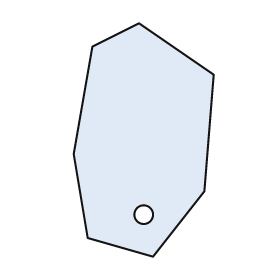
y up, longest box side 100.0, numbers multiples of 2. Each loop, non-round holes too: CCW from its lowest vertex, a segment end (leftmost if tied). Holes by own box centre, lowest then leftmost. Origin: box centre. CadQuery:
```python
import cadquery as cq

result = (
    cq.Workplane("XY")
    .moveTo(4.0, -50.0)
    .lineTo(26.0, -22.0)
    .lineTo(30.0, 28.0)
    .lineTo(-2.0, 50.0)
    .lineTo(-22.0, 40.0)
    .lineTo(-30.0, -6.0)
    .lineTo(-24.0, -42.0)
    .close()
    .moveTo(0.0, -32.0)
    .circle(4.0)
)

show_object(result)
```